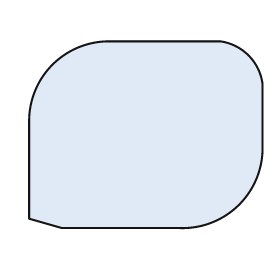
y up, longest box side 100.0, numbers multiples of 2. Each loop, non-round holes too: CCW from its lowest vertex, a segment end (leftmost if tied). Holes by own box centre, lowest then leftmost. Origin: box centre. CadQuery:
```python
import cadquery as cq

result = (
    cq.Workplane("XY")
    .moveTo(-36.0, -40.0)
    .lineTo(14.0, -40.0)
    .threePointArc((40.0, -30.0), (50.0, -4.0))
    .lineTo(50.0, 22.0)
    .threePointArc((44.0, 34.0), (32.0, 40.0))
    .lineTo(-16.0, 40.0)
    .threePointArc((-40.0, 30.0), (-50.0, 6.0))
    .lineTo(-50.0, -36.0)
    .close()
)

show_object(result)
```